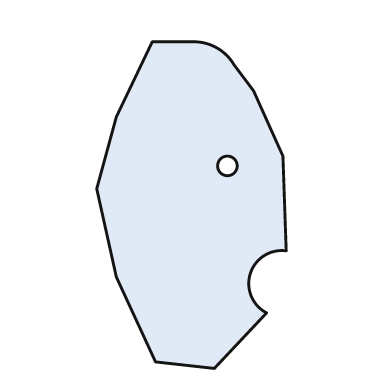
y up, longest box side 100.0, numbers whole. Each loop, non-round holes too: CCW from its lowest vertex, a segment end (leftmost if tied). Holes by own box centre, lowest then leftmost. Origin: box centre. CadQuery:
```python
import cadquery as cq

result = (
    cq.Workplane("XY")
    .moveTo(7.0, -50.0)
    .lineTo(23.0, -33.0)
    .threePointArc((18.0, -21.0), (29.0, -14.0))
    .lineTo(28.0, 15.0)
    .lineTo(19.0, 35.0)
    .lineTo(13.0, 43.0)
    .threePointArc((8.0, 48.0), (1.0, 50.0))
    .lineTo(-12.0, 50.0)
    .lineTo(-23.0, 27.0)
    .lineTo(-29.0, 5.0)
    .lineTo(-23.0, -22.0)
    .lineTo(-11.0, -48.0)
    .close()
    .moveTo(11.0, 12.0)
    .circle(3.0)
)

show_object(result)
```